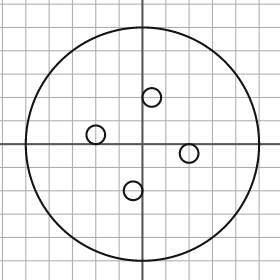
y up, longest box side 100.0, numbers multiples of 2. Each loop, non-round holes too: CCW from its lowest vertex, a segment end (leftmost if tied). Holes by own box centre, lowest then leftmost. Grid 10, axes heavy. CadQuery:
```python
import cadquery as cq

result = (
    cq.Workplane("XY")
    .moveTo(0.0, 0.0)
    .circle(50.0)
    .moveTo(-4.0, -20.0)
    .circle(4.0)
    .moveTo(20.0, -4.0)
    .circle(4.0)
    .moveTo(-20.0, 4.0)
    .circle(4.0)
    .moveTo(4.0, 20.0)
    .circle(4.0)
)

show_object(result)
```